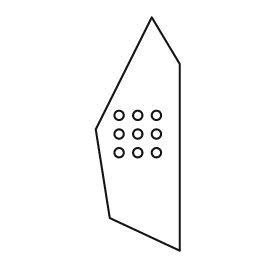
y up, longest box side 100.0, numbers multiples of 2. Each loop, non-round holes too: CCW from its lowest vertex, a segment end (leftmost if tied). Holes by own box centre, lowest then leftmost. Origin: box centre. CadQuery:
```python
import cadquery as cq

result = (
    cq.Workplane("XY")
    .moveTo(18.0, -50.0)
    .lineTo(18.0, 30.0)
    .lineTo(6.0, 50.0)
    .lineTo(-18.0, 2.0)
    .lineTo(-12.0, -36.0)
    .close()
    .moveTo(-8.0, -8.0)
    .circle(2.0)
    .moveTo(0.0, -8.0)
    .circle(2.0)
    .moveTo(8.0, -8.0)
    .circle(2.0)
    .moveTo(-8.0, 0.0)
    .circle(2.0)
    .moveTo(0.0, 0.0)
    .circle(2.0)
    .moveTo(8.0, 0.0)
    .circle(2.0)
    .moveTo(-8.0, 8.0)
    .circle(2.0)
    .moveTo(0.0, 8.0)
    .circle(2.0)
    .moveTo(8.0, 8.0)
    .circle(2.0)
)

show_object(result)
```